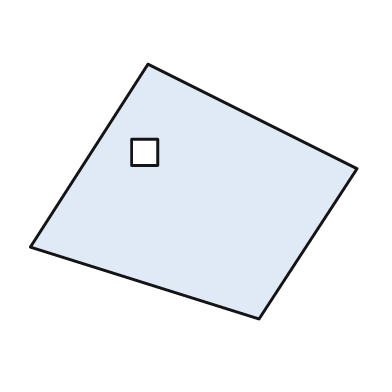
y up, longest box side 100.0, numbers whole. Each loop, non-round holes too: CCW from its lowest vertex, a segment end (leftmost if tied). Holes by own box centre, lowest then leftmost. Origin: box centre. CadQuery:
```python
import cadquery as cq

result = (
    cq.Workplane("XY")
    .moveTo(20.0, -39.0)
    .lineTo(50.0, 7.0)
    .lineTo(-14.0, 39.0)
    .lineTo(-50.0, -17.0)
    .close()
    .moveTo(-19.0, 8.0)
    .lineTo(-11.0, 8.0)
    .lineTo(-11.0, 16.0)
    .lineTo(-19.0, 16.0)
    .close()
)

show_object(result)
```